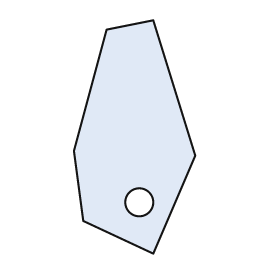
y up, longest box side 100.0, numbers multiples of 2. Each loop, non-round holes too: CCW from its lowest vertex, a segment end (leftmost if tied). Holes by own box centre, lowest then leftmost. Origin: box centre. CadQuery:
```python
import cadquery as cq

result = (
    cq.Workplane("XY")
    .moveTo(8.0, -50.0)
    .lineTo(26.0, -8.0)
    .lineTo(8.0, 50.0)
    .lineTo(-12.0, 46.0)
    .lineTo(-26.0, -6.0)
    .lineTo(-22.0, -36.0)
    .close()
    .moveTo(2.0, -28.0)
    .circle(6.0)
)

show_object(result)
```